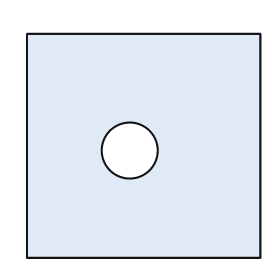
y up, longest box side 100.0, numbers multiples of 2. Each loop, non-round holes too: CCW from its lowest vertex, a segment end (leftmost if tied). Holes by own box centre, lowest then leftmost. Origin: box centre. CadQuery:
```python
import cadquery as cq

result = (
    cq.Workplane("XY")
    .moveTo(-50.0, -48.0)
    .lineTo(50.0, -48.0)
    .lineTo(50.0, 48.0)
    .lineTo(-50.0, 48.0)
    .close()
    .moveTo(-6.0, -2.0)
    .circle(12.0)
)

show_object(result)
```